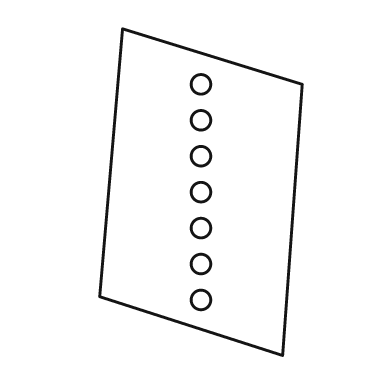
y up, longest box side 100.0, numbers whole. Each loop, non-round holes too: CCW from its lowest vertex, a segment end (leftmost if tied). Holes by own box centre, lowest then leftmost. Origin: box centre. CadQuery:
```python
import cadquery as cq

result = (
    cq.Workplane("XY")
    .moveTo(25.0, -50.0)
    .lineTo(31.0, 33.0)
    .lineTo(-24.0, 50.0)
    .lineTo(-31.0, -32.0)
    .close()
    .moveTo(0.0, -33.0)
    .circle(3.0)
    .moveTo(0.0, -22.0)
    .circle(3.0)
    .moveTo(0.0, -11.0)
    .circle(3.0)
    .moveTo(0.0, 0.0)
    .circle(3.0)
    .moveTo(0.0, 11.0)
    .circle(3.0)
    .moveTo(0.0, 22.0)
    .circle(3.0)
    .moveTo(0.0, 33.0)
    .circle(3.0)
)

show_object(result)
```